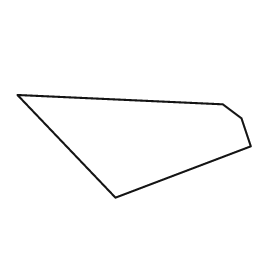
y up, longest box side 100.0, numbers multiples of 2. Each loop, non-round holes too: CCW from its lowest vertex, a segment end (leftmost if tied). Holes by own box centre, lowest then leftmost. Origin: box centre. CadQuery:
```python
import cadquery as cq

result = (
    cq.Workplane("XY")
    .moveTo(-8.0, -22.0)
    .lineTo(50.0, 0.0)
    .lineTo(46.0, 12.0)
    .lineTo(38.0, 18.0)
    .lineTo(-50.0, 22.0)
    .close()
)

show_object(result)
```